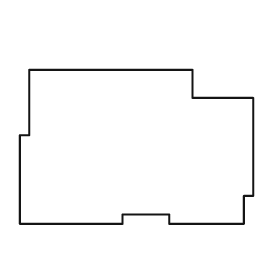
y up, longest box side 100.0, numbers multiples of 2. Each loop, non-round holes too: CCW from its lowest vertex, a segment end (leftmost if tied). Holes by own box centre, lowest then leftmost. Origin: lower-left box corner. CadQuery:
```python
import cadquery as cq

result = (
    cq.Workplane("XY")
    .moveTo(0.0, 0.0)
    .lineTo(44.0, 0.0)
    .lineTo(44.0, 4.0)
    .lineTo(64.0, 4.0)
    .lineTo(64.0, 0.0)
    .lineTo(96.0, 0.0)
    .lineTo(96.0, 12.0)
    .lineTo(100.0, 12.0)
    .lineTo(100.0, 54.0)
    .lineTo(74.0, 54.0)
    .lineTo(74.0, 66.0)
    .lineTo(4.0, 66.0)
    .lineTo(4.0, 38.0)
    .lineTo(0.0, 38.0)
    .close()
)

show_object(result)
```